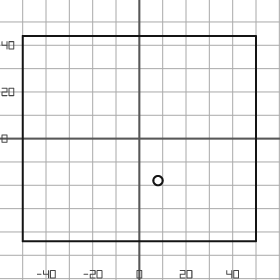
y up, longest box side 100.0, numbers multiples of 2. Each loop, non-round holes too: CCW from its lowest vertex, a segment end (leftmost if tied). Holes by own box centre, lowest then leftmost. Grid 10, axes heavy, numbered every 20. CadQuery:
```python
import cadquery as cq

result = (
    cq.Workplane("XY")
    .moveTo(-50.0, -44.0)
    .lineTo(50.0, -44.0)
    .lineTo(50.0, 44.0)
    .lineTo(-50.0, 44.0)
    .close()
    .moveTo(8.0, -18.0)
    .circle(2.0)
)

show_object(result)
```